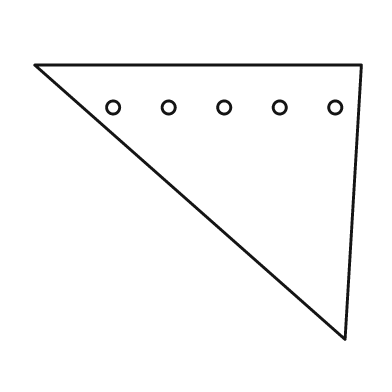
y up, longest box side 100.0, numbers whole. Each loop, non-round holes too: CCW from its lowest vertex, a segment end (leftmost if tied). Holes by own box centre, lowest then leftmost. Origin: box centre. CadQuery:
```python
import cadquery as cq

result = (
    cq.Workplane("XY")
    .moveTo(45.0, -42.0)
    .lineTo(50.0, 42.0)
    .lineTo(-50.0, 42.0)
    .close()
    .moveTo(-26.0, 29.0)
    .circle(2.0)
    .moveTo(-9.0, 29.0)
    .circle(2.0)
    .moveTo(8.0, 29.0)
    .circle(2.0)
    .moveTo(25.0, 29.0)
    .circle(2.0)
    .moveTo(42.0, 29.0)
    .circle(2.0)
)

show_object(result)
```